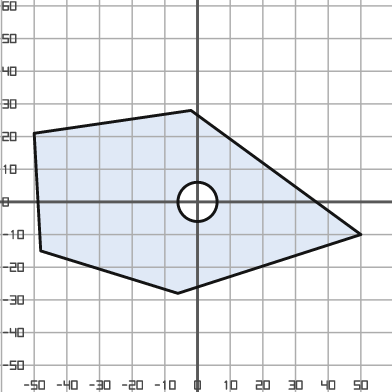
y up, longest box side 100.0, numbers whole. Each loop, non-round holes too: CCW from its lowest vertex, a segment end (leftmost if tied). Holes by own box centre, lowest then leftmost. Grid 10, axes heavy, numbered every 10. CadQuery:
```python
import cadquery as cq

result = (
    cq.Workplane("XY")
    .moveTo(-6.0, -28.0)
    .lineTo(50.0, -10.0)
    .lineTo(-2.0, 28.0)
    .lineTo(-50.0, 21.0)
    .lineTo(-48.0, -15.0)
    .close()
    .moveTo(0.0, 0.0)
    .circle(6.0)
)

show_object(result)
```